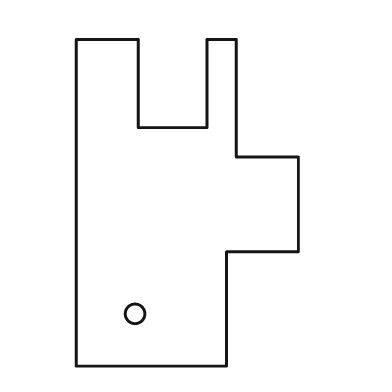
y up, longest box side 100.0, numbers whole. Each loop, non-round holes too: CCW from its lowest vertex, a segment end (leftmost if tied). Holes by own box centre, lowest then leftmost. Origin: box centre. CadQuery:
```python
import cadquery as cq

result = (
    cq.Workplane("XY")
    .moveTo(-34.0, -50.0)
    .lineTo(12.0, -50.0)
    .lineTo(12.0, -15.0)
    .lineTo(34.0, -15.0)
    .lineTo(34.0, 14.0)
    .lineTo(15.0, 14.0)
    .lineTo(15.0, 50.0)
    .lineTo(6.0, 50.0)
    .lineTo(6.0, 23.0)
    .lineTo(-15.0, 23.0)
    .lineTo(-15.0, 50.0)
    .lineTo(-34.0, 50.0)
    .close()
    .moveTo(-16.0, -34.0)
    .circle(3.0)
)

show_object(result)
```